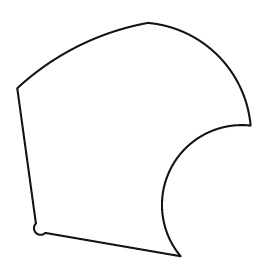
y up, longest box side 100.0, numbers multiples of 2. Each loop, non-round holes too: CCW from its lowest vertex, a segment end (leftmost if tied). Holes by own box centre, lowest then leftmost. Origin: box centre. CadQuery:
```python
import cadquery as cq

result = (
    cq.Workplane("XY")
    .moveTo(20.0, -50.0)
    .threePointArc((16.0, -12.0), (50.0, 6.0))
    .threePointArc((36.0, 36.0), (6.0, 50.0))
    .threePointArc((-24.0, 40.0), (-50.0, 22.0))
    .lineTo(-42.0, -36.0)
    .threePointArc((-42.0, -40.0), (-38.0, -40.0))
    .close()
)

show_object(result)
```